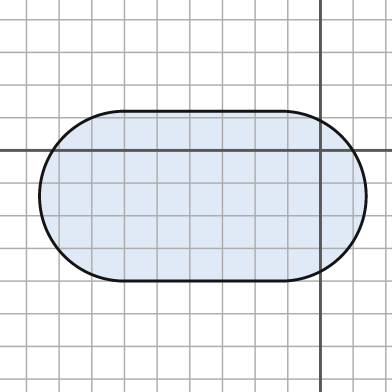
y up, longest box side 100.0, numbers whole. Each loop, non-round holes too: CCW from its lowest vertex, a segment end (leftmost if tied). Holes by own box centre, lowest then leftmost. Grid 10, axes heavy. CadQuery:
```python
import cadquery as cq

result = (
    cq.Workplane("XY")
    .moveTo(-60.0, -40.0)
    .lineTo(-12.0, -40.0)
    .threePointArc((14.0, -14.0), (-12.0, 12.0))
    .lineTo(-60.0, 12.0)
    .threePointArc((-86.0, -14.0), (-60.0, -40.0))
    .close()
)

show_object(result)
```